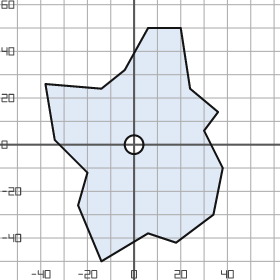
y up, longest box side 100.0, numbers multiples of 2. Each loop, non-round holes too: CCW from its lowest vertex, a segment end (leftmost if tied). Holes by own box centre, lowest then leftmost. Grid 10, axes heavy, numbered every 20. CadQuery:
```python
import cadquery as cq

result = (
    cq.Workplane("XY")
    .moveTo(-14.0, -50.0)
    .lineTo(6.0, -38.0)
    .lineTo(18.0, -42.0)
    .lineTo(34.0, -30.0)
    .lineTo(38.0, -10.0)
    .lineTo(30.0, 6.0)
    .lineTo(36.0, 14.0)
    .lineTo(24.0, 24.0)
    .lineTo(20.0, 50.0)
    .lineTo(6.0, 50.0)
    .lineTo(-4.0, 32.0)
    .lineTo(-14.0, 24.0)
    .lineTo(-38.0, 26.0)
    .lineTo(-34.0, 2.0)
    .lineTo(-20.0, -12.0)
    .lineTo(-24.0, -26.0)
    .close()
    .moveTo(0.0, 0.0)
    .circle(4.0)
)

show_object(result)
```